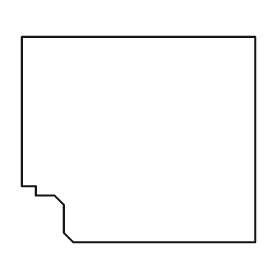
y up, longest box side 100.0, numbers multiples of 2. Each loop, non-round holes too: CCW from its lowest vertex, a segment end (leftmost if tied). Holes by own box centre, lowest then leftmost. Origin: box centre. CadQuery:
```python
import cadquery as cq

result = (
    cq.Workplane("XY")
    .moveTo(-28.0, -44.0)
    .lineTo(50.0, -44.0)
    .lineTo(50.0, 44.0)
    .lineTo(-50.0, 44.0)
    .lineTo(-50.0, -20.0)
    .lineTo(-44.0, -20.0)
    .lineTo(-44.0, -24.0)
    .lineTo(-36.0, -24.0)
    .lineTo(-32.0, -28.0)
    .lineTo(-32.0, -40.0)
    .close()
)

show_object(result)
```